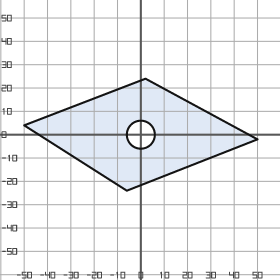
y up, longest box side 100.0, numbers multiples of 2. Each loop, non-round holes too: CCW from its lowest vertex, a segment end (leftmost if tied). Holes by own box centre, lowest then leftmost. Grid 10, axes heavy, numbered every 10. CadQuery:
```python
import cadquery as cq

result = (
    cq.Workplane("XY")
    .moveTo(-6.0, -24.0)
    .lineTo(50.0, -2.0)
    .lineTo(2.0, 24.0)
    .lineTo(-50.0, 4.0)
    .close()
    .moveTo(0.0, 0.0)
    .circle(6.0)
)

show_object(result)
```